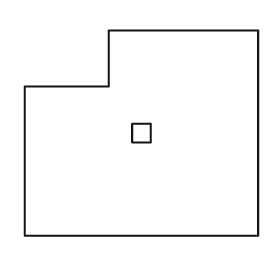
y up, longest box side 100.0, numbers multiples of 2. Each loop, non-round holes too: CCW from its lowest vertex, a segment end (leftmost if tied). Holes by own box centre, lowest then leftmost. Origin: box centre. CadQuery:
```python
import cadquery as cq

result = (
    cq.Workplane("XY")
    .moveTo(-50.0, -44.0)
    .lineTo(50.0, -44.0)
    .lineTo(50.0, 44.0)
    .lineTo(-14.0, 44.0)
    .lineTo(-14.0, 20.0)
    .lineTo(-50.0, 20.0)
    .close()
    .moveTo(-4.0, -4.0)
    .lineTo(4.0, -4.0)
    .lineTo(4.0, 4.0)
    .lineTo(-4.0, 4.0)
    .close()
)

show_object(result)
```